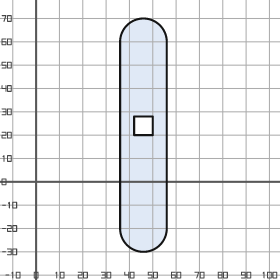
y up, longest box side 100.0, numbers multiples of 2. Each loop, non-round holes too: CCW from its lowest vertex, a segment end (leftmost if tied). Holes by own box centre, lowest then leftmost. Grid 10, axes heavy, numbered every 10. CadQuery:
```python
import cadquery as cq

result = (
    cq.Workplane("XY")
    .moveTo(36.0, -20.0)
    .threePointArc((46.0, -30.0), (56.0, -20.0))
    .lineTo(56.0, 60.0)
    .threePointArc((46.0, 70.0), (36.0, 60.0))
    .close()
    .moveTo(42.0, 20.0)
    .lineTo(50.0, 20.0)
    .lineTo(50.0, 28.0)
    .lineTo(42.0, 28.0)
    .close()
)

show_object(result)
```